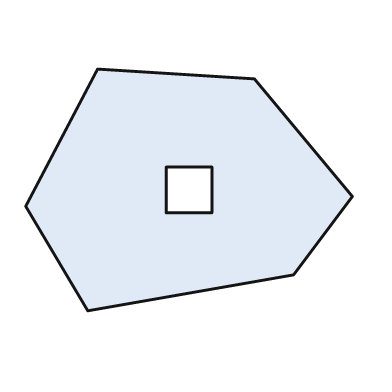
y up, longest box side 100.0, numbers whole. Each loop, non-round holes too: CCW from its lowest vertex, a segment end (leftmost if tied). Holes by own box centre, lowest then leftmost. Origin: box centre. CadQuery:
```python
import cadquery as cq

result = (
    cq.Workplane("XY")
    .moveTo(-31.0, -37.0)
    .lineTo(32.0, -26.0)
    .lineTo(50.0, -2.0)
    .lineTo(20.0, 34.0)
    .lineTo(-28.0, 37.0)
    .lineTo(-50.0, -5.0)
    .close()
    .moveTo(-7.0, -7.0)
    .lineTo(7.0, -7.0)
    .lineTo(7.0, 7.0)
    .lineTo(-7.0, 7.0)
    .close()
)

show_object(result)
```